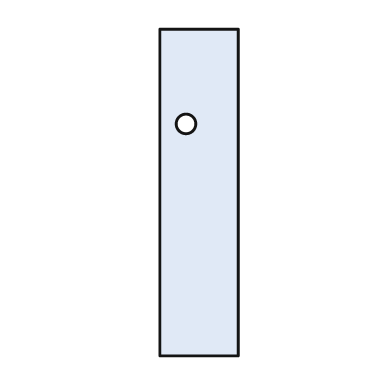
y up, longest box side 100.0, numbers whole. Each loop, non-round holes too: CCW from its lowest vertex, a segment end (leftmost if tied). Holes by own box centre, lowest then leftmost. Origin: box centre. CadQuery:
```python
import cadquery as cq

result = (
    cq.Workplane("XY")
    .moveTo(-12.0, -50.0)
    .lineTo(12.0, -50.0)
    .lineTo(12.0, 50.0)
    .lineTo(-12.0, 50.0)
    .close()
    .moveTo(-4.0, 21.0)
    .circle(3.0)
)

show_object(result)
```